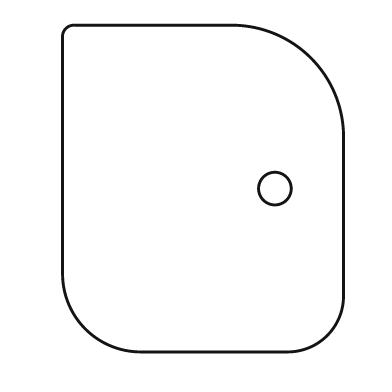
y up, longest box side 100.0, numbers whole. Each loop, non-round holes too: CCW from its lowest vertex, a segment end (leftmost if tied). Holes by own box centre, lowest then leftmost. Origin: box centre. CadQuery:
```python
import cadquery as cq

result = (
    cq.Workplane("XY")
    .moveTo(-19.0, -50.0)
    .lineTo(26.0, -50.0)
    .threePointArc((38.0, -45.0), (43.0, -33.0))
    .lineTo(43.0, 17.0)
    .threePointArc((33.0, 40.0), (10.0, 50.0))
    .lineTo(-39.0, 50.0)
    .threePointArc((-42.0, 49.0), (-43.0, 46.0))
    .lineTo(-43.0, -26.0)
    .threePointArc((-36.0, -43.0), (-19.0, -50.0))
    .close()
    .moveTo(22.0, 0.0)
    .circle(5.0)
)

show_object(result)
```